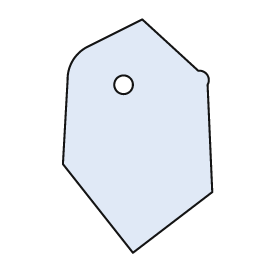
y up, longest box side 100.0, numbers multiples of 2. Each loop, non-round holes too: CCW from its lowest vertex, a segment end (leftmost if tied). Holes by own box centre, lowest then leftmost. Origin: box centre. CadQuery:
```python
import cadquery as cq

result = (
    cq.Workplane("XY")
    .moveTo(-2.0, -50.0)
    .lineTo(32.0, -24.0)
    .lineTo(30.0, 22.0)
    .threePointArc((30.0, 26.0), (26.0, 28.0))
    .lineTo(2.0, 50.0)
    .lineTo(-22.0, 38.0)
    .threePointArc((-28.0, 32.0), (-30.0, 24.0))
    .lineTo(-32.0, -12.0)
    .close()
    .moveTo(-6.0, 22.0)
    .circle(4.0)
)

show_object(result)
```